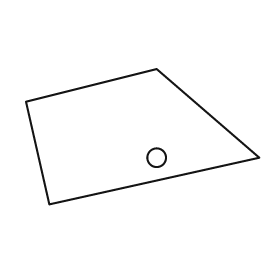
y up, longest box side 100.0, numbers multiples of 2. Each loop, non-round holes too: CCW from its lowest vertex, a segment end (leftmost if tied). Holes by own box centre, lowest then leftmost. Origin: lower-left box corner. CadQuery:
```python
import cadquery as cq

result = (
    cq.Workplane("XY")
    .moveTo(10.0, 0.0)
    .lineTo(100.0, 20.0)
    .lineTo(56.0, 58.0)
    .lineTo(0.0, 44.0)
    .close()
    .moveTo(56.0, 20.0)
    .circle(4.0)
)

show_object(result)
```